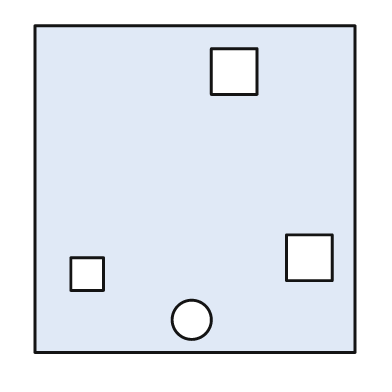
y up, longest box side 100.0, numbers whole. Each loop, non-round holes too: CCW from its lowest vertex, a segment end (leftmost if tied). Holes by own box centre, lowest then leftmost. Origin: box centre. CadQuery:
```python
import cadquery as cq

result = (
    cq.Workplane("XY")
    .moveTo(-49.0, -50.0)
    .lineTo(49.0, -50.0)
    .lineTo(49.0, 50.0)
    .lineTo(-49.0, 50.0)
    .close()
    .moveTo(-1.0, -40.0)
    .circle(6.0)
    .moveTo(-38.0, -31.0)
    .lineTo(-28.0, -31.0)
    .lineTo(-28.0, -21.0)
    .lineTo(-38.0, -21.0)
    .close()
    .moveTo(28.0, -28.0)
    .lineTo(42.0, -28.0)
    .lineTo(42.0, -14.0)
    .lineTo(28.0, -14.0)
    .close()
    .moveTo(5.0, 29.0)
    .lineTo(19.0, 29.0)
    .lineTo(19.0, 43.0)
    .lineTo(5.0, 43.0)
    .close()
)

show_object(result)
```